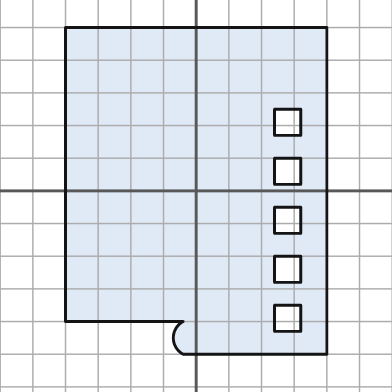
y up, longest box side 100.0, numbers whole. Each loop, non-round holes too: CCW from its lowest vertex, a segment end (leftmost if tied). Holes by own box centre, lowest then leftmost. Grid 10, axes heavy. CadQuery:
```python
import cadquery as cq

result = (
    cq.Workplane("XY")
    .moveTo(-4.0, -50.0)
    .lineTo(40.0, -50.0)
    .lineTo(40.0, 50.0)
    .lineTo(-40.0, 50.0)
    .lineTo(-40.0, -40.0)
    .lineTo(-4.0, -40.0)
    .threePointArc((-7.0, -45.0), (-4.0, -50.0))
    .close()
    .moveTo(24.0, -43.0)
    .lineTo(32.0, -43.0)
    .lineTo(32.0, -35.0)
    .lineTo(24.0, -35.0)
    .close()
    .moveTo(24.0, -28.0)
    .lineTo(32.0, -28.0)
    .lineTo(32.0, -20.0)
    .lineTo(24.0, -20.0)
    .close()
    .moveTo(24.0, -13.0)
    .lineTo(32.0, -13.0)
    .lineTo(32.0, -5.0)
    .lineTo(24.0, -5.0)
    .close()
    .moveTo(24.0, 2.0)
    .lineTo(32.0, 2.0)
    .lineTo(32.0, 10.0)
    .lineTo(24.0, 10.0)
    .close()
    .moveTo(24.0, 17.0)
    .lineTo(32.0, 17.0)
    .lineTo(32.0, 25.0)
    .lineTo(24.0, 25.0)
    .close()
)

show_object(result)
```